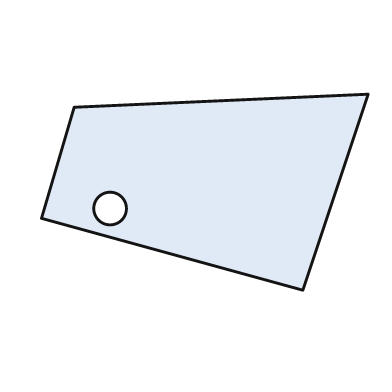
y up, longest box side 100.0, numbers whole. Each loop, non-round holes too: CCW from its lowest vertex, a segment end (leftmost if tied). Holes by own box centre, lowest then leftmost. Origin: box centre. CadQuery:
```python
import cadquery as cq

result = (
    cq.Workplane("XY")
    .moveTo(30.0, -30.0)
    .lineTo(50.0, 30.0)
    .lineTo(-40.0, 26.0)
    .lineTo(-50.0, -8.0)
    .close()
    .moveTo(-29.0, -5.0)
    .circle(5.0)
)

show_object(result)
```